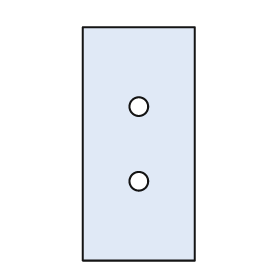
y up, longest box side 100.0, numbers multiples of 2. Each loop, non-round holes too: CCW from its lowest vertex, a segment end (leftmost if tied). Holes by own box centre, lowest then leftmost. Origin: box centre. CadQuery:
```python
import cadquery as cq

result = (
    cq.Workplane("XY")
    .moveTo(-24.0, -50.0)
    .lineTo(24.0, -50.0)
    .lineTo(24.0, 50.0)
    .lineTo(-24.0, 50.0)
    .close()
    .moveTo(0.0, -16.0)
    .circle(4.0)
    .moveTo(0.0, 16.0)
    .circle(4.0)
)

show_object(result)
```